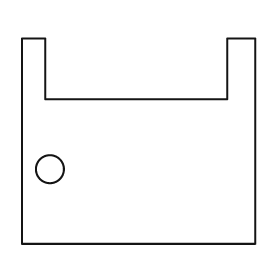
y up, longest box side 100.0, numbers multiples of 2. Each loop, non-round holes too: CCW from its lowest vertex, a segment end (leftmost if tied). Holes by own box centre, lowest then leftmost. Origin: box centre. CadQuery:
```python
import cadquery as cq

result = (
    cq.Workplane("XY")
    .moveTo(-50.0, -44.0)
    .lineTo(50.0, -44.0)
    .lineTo(50.0, 44.0)
    .lineTo(38.0, 44.0)
    .lineTo(38.0, 18.0)
    .lineTo(-40.0, 18.0)
    .lineTo(-40.0, 44.0)
    .lineTo(-50.0, 44.0)
    .close()
    .moveTo(-38.0, -12.0)
    .circle(6.0)
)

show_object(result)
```